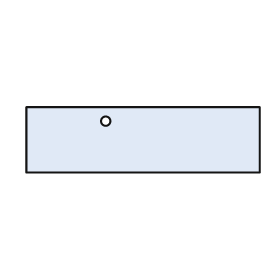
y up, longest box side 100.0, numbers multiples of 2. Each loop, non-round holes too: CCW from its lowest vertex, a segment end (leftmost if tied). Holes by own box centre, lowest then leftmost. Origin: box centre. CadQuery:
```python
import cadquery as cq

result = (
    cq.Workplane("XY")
    .moveTo(-50.0, -14.0)
    .lineTo(50.0, -14.0)
    .lineTo(50.0, 14.0)
    .lineTo(-50.0, 14.0)
    .close()
    .moveTo(-16.0, 8.0)
    .circle(2.0)
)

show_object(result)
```